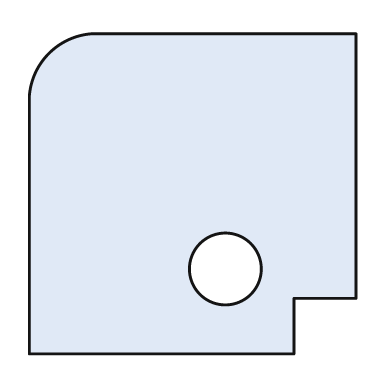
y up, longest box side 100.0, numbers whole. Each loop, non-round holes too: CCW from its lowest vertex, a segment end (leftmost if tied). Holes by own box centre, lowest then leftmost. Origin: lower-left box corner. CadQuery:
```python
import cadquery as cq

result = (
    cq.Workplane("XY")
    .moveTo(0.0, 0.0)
    .lineTo(81.0, 0.0)
    .lineTo(81.0, 17.0)
    .lineTo(100.0, 17.0)
    .lineTo(100.0, 98.0)
    .lineTo(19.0, 98.0)
    .threePointArc((6.0, 92.0), (0.0, 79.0))
    .close()
    .moveTo(60.0, 26.0)
    .circle(11.0)
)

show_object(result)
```